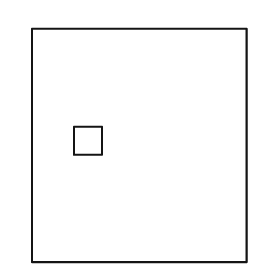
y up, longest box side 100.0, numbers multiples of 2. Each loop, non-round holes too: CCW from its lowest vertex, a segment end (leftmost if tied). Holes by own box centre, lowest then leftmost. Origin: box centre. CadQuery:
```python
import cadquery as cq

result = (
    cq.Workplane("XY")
    .moveTo(-46.0, -50.0)
    .lineTo(46.0, -50.0)
    .lineTo(46.0, 50.0)
    .lineTo(-46.0, 50.0)
    .close()
    .moveTo(-28.0, -4.0)
    .lineTo(-16.0, -4.0)
    .lineTo(-16.0, 8.0)
    .lineTo(-28.0, 8.0)
    .close()
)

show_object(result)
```